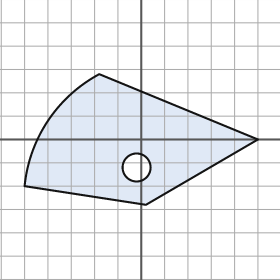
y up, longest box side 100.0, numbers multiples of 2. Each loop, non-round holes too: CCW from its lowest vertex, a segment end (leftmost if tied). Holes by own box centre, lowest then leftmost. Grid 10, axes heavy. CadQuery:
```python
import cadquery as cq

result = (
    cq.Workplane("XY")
    .moveTo(2.0, -28.0)
    .lineTo(50.0, 0.0)
    .lineTo(-18.0, 28.0)
    .threePointArc((-40.0, 8.0), (-50.0, -20.0))
    .close()
    .moveTo(-2.0, -12.0)
    .circle(6.0)
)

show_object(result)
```